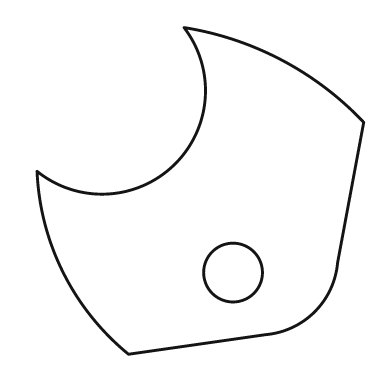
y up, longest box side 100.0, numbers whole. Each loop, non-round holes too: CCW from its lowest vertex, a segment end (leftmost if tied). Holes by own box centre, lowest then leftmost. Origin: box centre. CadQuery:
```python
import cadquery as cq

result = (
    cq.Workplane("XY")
    .moveTo(-22.0, -50.0)
    .lineTo(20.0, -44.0)
    .threePointArc((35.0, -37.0), (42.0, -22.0))
    .lineTo(50.0, 21.0)
    .threePointArc((25.0, 40.0), (-5.0, 50.0))
    .threePointArc((-8.0, 8.0), (-50.0, 6.0))
    .threePointArc((-42.0, -25.0), (-22.0, -50.0))
    .close()
    .moveTo(10.0, -25.0)
    .circle(9.0)
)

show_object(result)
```